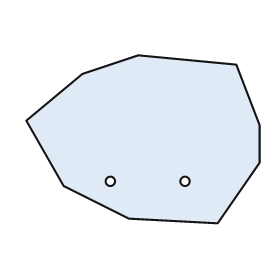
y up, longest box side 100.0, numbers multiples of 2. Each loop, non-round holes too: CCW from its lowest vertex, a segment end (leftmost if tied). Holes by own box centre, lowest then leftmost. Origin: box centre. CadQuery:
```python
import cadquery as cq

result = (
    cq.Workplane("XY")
    .moveTo(32.0, -36.0)
    .lineTo(50.0, -10.0)
    .lineTo(50.0, 6.0)
    .lineTo(40.0, 32.0)
    .lineTo(-2.0, 36.0)
    .lineTo(-26.0, 28.0)
    .lineTo(-50.0, 8.0)
    .lineTo(-34.0, -20.0)
    .lineTo(-6.0, -34.0)
    .close()
    .moveTo(-14.0, -18.0)
    .circle(2.0)
    .moveTo(18.0, -18.0)
    .circle(2.0)
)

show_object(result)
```